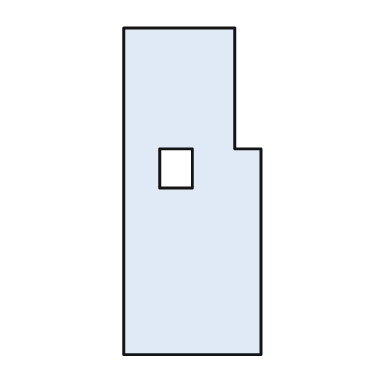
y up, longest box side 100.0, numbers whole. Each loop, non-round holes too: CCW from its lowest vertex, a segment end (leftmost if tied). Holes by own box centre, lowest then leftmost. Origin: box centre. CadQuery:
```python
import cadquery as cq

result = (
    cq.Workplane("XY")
    .moveTo(-21.0, -50.0)
    .lineTo(21.0, -50.0)
    .lineTo(21.0, 13.0)
    .lineTo(13.0, 13.0)
    .lineTo(13.0, 50.0)
    .lineTo(-21.0, 50.0)
    .close()
    .moveTo(-10.0, 1.0)
    .lineTo(0.0, 1.0)
    .lineTo(0.0, 13.0)
    .lineTo(-10.0, 13.0)
    .close()
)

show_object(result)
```